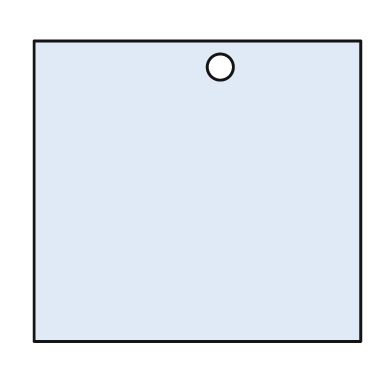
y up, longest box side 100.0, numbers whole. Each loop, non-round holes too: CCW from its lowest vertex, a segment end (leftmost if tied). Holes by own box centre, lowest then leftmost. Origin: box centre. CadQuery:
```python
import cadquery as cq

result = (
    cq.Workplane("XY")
    .moveTo(-50.0, -46.0)
    .lineTo(50.0, -46.0)
    .lineTo(50.0, 46.0)
    .lineTo(-50.0, 46.0)
    .close()
    .moveTo(7.0, 38.0)
    .circle(4.0)
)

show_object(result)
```